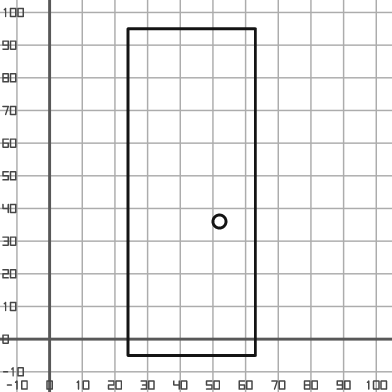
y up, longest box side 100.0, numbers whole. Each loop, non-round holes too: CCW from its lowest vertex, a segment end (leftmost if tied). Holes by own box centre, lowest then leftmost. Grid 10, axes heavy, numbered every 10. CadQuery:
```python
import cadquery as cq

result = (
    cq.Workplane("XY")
    .moveTo(24.0, -5.0)
    .lineTo(63.0, -5.0)
    .lineTo(63.0, 95.0)
    .lineTo(24.0, 95.0)
    .close()
    .moveTo(52.0, 36.0)
    .circle(2.0)
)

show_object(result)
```